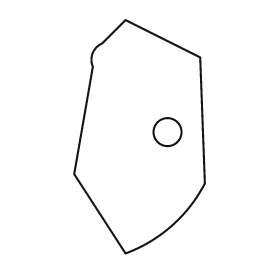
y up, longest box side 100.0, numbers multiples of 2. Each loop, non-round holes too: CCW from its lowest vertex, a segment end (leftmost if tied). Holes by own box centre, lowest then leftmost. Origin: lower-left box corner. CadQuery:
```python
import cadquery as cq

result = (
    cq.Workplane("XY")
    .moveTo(22.0, 0.0)
    .threePointArc((42.0, 12.0), (56.0, 30.0))
    .lineTo(54.0, 84.0)
    .lineTo(22.0, 100.0)
    .lineTo(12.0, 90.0)
    .threePointArc((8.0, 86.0), (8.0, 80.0))
    .lineTo(0.0, 34.0)
    .close()
    .moveTo(40.0, 52.0)
    .circle(6.0)
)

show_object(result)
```